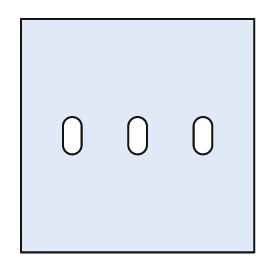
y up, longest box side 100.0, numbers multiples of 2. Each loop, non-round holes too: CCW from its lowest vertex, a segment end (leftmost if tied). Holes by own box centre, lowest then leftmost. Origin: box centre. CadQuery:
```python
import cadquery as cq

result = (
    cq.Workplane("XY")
    .moveTo(-50.0, -50.0)
    .lineTo(50.0, -50.0)
    .lineTo(50.0, 50.0)
    .lineTo(-50.0, 50.0)
    .close()
    .moveTo(-32.0, -4.0)
    .threePointArc((-28.0, -8.0), (-24.0, -4.0))
    .lineTo(-24.0, 4.0)
    .threePointArc((-28.0, 8.0), (-32.0, 4.0))
    .close()
    .moveTo(-4.0, -4.0)
    .threePointArc((0.0, -8.0), (4.0, -4.0))
    .lineTo(4.0, 4.0)
    .threePointArc((0.0, 8.0), (-4.0, 4.0))
    .close()
    .moveTo(24.0, -4.0)
    .threePointArc((28.0, -8.0), (32.0, -4.0))
    .lineTo(32.0, 4.0)
    .threePointArc((28.0, 8.0), (24.0, 4.0))
    .close()
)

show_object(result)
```